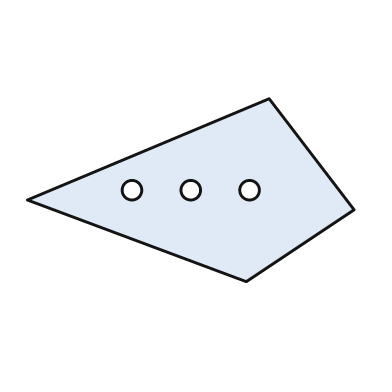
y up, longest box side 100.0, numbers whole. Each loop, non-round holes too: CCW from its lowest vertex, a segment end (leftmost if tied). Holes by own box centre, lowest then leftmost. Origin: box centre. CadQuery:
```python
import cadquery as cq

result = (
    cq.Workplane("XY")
    .moveTo(17.0, -28.0)
    .lineTo(50.0, -6.0)
    .lineTo(24.0, 28.0)
    .lineTo(-50.0, -3.0)
    .close()
    .moveTo(-18.0, 0.0)
    .circle(3.0)
    .moveTo(0.0, 0.0)
    .circle(3.0)
    .moveTo(18.0, 0.0)
    .circle(3.0)
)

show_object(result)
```